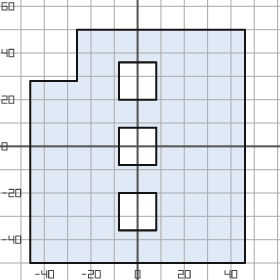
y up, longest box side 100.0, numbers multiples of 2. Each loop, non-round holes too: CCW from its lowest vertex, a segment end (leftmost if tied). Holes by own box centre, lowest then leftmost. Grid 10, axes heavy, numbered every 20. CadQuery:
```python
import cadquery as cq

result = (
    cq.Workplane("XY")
    .moveTo(-46.0, -50.0)
    .lineTo(46.0, -50.0)
    .lineTo(46.0, 50.0)
    .lineTo(-26.0, 50.0)
    .lineTo(-26.0, 28.0)
    .lineTo(-46.0, 28.0)
    .close()
    .moveTo(-8.0, -36.0)
    .lineTo(8.0, -36.0)
    .lineTo(8.0, -20.0)
    .lineTo(-8.0, -20.0)
    .close()
    .moveTo(-8.0, -8.0)
    .lineTo(8.0, -8.0)
    .lineTo(8.0, 8.0)
    .lineTo(-8.0, 8.0)
    .close()
    .moveTo(-8.0, 20.0)
    .lineTo(8.0, 20.0)
    .lineTo(8.0, 36.0)
    .lineTo(-8.0, 36.0)
    .close()
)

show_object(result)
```